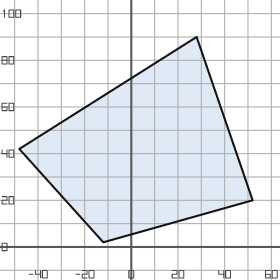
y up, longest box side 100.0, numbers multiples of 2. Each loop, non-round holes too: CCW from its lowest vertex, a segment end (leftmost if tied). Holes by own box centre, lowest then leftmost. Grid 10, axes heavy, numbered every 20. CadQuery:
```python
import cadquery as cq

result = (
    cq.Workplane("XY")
    .moveTo(-12.0, 2.0)
    .lineTo(52.0, 20.0)
    .lineTo(28.0, 90.0)
    .lineTo(-48.0, 42.0)
    .close()
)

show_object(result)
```